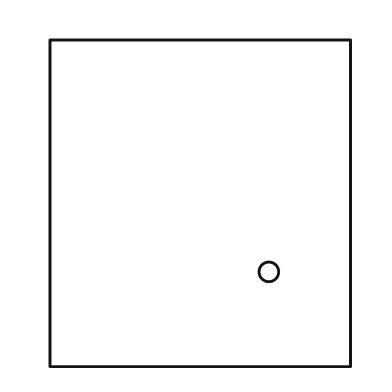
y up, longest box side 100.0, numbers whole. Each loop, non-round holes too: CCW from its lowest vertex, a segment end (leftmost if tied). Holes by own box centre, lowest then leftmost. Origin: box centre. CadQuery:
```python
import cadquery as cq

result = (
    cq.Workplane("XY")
    .moveTo(-46.0, -50.0)
    .lineTo(46.0, -50.0)
    .lineTo(46.0, 50.0)
    .lineTo(-46.0, 50.0)
    .close()
    .moveTo(21.0, -21.0)
    .circle(3.0)
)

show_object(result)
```